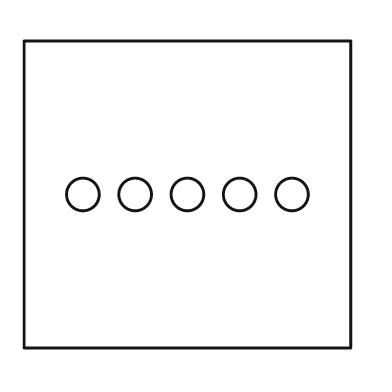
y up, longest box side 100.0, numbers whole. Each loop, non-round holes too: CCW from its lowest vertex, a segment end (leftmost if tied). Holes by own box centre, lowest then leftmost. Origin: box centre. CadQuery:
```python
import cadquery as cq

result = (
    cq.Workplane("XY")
    .moveTo(-50.0, -47.0)
    .lineTo(50.0, -47.0)
    .lineTo(50.0, 47.0)
    .lineTo(-50.0, 47.0)
    .close()
    .moveTo(-32.0, 0.0)
    .circle(5.0)
    .moveTo(-16.0, 0.0)
    .circle(5.0)
    .moveTo(0.0, 0.0)
    .circle(5.0)
    .moveTo(16.0, 0.0)
    .circle(5.0)
    .moveTo(32.0, 0.0)
    .circle(5.0)
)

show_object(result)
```